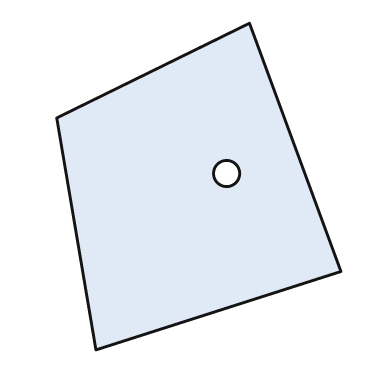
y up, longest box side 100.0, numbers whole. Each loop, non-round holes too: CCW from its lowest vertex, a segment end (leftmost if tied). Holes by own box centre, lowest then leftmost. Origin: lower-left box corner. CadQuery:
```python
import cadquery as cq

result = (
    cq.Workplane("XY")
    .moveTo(12.0, 0.0)
    .lineTo(87.0, 24.0)
    .lineTo(59.0, 100.0)
    .lineTo(0.0, 71.0)
    .close()
    .moveTo(52.0, 54.0)
    .circle(4.0)
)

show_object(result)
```